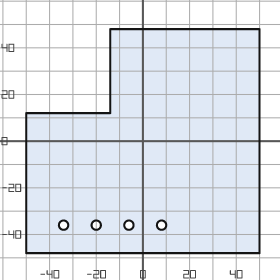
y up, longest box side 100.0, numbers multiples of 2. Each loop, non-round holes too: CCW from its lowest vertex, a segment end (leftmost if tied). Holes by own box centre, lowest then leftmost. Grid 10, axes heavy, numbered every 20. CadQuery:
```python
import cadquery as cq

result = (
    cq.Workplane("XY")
    .moveTo(-50.0, -48.0)
    .lineTo(50.0, -48.0)
    .lineTo(50.0, 48.0)
    .lineTo(-14.0, 48.0)
    .lineTo(-14.0, 12.0)
    .lineTo(-50.0, 12.0)
    .close()
    .moveTo(-34.0, -36.0)
    .circle(2.0)
    .moveTo(-20.0, -36.0)
    .circle(2.0)
    .moveTo(-6.0, -36.0)
    .circle(2.0)
    .moveTo(8.0, -36.0)
    .circle(2.0)
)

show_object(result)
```